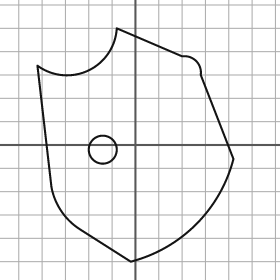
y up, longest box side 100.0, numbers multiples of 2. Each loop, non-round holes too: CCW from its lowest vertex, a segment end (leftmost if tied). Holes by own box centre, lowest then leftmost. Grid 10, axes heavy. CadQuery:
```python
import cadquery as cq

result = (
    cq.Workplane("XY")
    .moveTo(-2.0, -50.0)
    .threePointArc((26.0, -34.0), (42.0, -6.0))
    .lineTo(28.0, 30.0)
    .threePointArc((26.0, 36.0), (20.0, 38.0))
    .lineTo(-8.0, 50.0)
    .threePointArc((-20.0, 32.0), (-42.0, 34.0))
    .lineTo(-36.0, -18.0)
    .threePointArc((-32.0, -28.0), (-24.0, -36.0))
    .close()
    .moveTo(-14.0, -2.0)
    .circle(6.0)
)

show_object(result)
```